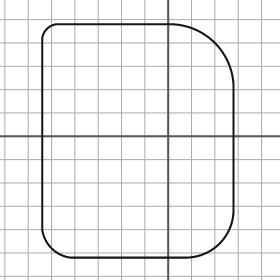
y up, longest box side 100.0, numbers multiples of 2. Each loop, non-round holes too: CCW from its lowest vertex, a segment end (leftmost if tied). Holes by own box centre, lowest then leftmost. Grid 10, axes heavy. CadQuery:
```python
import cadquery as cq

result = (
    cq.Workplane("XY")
    .moveTo(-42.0, -52.0)
    .lineTo(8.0, -52.0)
    .threePointArc((22.0, -46.0), (28.0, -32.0))
    .lineTo(28.0, 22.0)
    .threePointArc((20.0, 40.0), (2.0, 48.0))
    .lineTo(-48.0, 48.0)
    .threePointArc((-52.0, 46.0), (-54.0, 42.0))
    .lineTo(-54.0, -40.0)
    .threePointArc((-50.0, -48.0), (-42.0, -52.0))
    .close()
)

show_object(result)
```